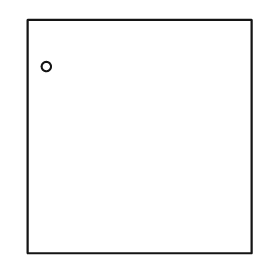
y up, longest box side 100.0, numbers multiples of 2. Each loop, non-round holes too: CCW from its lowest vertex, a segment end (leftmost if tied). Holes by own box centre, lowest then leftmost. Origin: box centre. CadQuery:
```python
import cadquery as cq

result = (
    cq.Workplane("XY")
    .moveTo(-48.0, -50.0)
    .lineTo(48.0, -50.0)
    .lineTo(48.0, 50.0)
    .lineTo(-48.0, 50.0)
    .close()
    .moveTo(-40.0, 30.0)
    .circle(2.0)
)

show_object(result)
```